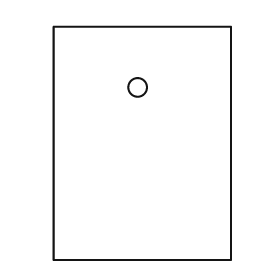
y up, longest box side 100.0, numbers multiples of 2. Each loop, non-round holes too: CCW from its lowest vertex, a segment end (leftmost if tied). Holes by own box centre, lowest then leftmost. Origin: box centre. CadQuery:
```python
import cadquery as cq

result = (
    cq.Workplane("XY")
    .moveTo(-38.0, -50.0)
    .lineTo(38.0, -50.0)
    .lineTo(38.0, 50.0)
    .lineTo(-38.0, 50.0)
    .close()
    .moveTo(-2.0, 24.0)
    .circle(4.0)
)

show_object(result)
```